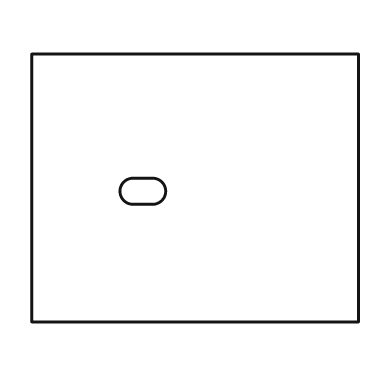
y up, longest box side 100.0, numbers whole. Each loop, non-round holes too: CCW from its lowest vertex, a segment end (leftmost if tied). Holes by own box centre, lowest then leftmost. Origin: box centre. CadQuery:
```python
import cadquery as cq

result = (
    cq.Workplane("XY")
    .moveTo(-50.0, -41.0)
    .lineTo(50.0, -41.0)
    .lineTo(50.0, 41.0)
    .lineTo(-50.0, 41.0)
    .close()
    .moveTo(-19.0, -5.0)
    .lineTo(-13.0, -5.0)
    .threePointArc((-9.0, -1.0), (-13.0, 3.0))
    .lineTo(-19.0, 3.0)
    .threePointArc((-23.0, -1.0), (-19.0, -5.0))
    .close()
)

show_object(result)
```